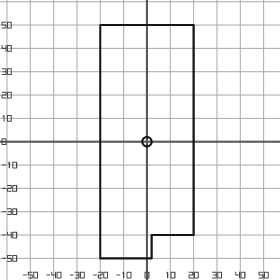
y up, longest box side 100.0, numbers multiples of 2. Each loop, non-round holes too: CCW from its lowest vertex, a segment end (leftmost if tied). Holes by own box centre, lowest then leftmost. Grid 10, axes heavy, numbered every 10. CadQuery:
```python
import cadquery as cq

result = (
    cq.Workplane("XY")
    .moveTo(-20.0, -50.0)
    .lineTo(2.0, -50.0)
    .lineTo(2.0, -40.0)
    .lineTo(20.0, -40.0)
    .lineTo(20.0, 50.0)
    .lineTo(-20.0, 50.0)
    .close()
    .moveTo(0.0, 0.0)
    .circle(2.0)
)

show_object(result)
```